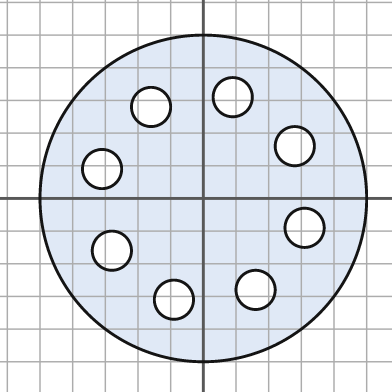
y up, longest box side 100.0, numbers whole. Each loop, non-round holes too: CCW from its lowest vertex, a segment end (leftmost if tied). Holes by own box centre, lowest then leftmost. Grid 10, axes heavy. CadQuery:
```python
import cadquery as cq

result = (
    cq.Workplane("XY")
    .moveTo(0.0, 0.0)
    .circle(50.0)
    .moveTo(-9.0, -31.0)
    .circle(6.0)
    .moveTo(16.0, -28.0)
    .circle(6.0)
    .moveTo(-28.0, -16.0)
    .circle(6.0)
    .moveTo(31.0, -9.0)
    .circle(6.0)
    .moveTo(-31.0, 9.0)
    .circle(6.0)
    .moveTo(28.0, 16.0)
    .circle(6.0)
    .moveTo(-16.0, 28.0)
    .circle(6.0)
    .moveTo(9.0, 31.0)
    .circle(6.0)
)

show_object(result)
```